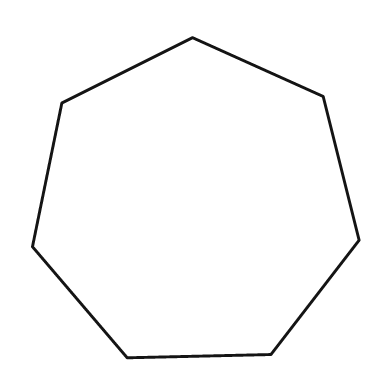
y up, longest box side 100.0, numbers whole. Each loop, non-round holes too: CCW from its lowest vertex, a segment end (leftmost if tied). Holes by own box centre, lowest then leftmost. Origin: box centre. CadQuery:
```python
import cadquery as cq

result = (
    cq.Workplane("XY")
    .moveTo(-21.0, -49.0)
    .lineTo(23.0, -48.0)
    .lineTo(50.0, -13.0)
    .lineTo(39.0, 31.0)
    .lineTo(-1.0, 49.0)
    .lineTo(-41.0, 29.0)
    .lineTo(-50.0, -15.0)
    .close()
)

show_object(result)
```